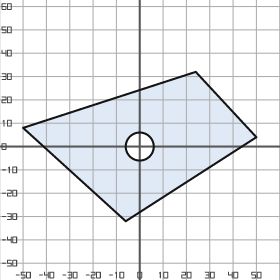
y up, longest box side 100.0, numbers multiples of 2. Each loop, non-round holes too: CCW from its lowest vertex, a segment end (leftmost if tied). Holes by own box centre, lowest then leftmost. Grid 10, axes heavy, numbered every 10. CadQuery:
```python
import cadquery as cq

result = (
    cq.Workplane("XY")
    .moveTo(-6.0, -32.0)
    .lineTo(50.0, 4.0)
    .lineTo(24.0, 32.0)
    .lineTo(-50.0, 8.0)
    .close()
    .moveTo(0.0, 0.0)
    .circle(6.0)
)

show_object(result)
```